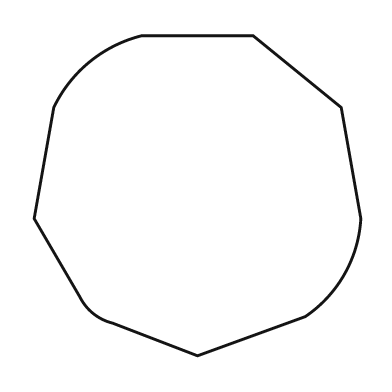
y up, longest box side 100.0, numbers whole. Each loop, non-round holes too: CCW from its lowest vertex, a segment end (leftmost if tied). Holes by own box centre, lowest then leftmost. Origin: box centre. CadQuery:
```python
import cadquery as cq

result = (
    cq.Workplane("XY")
    .moveTo(0.0, -49.0)
    .lineTo(33.0, -37.0)
    .threePointArc((45.0, -24.0), (50.0, -7.0))
    .lineTo(44.0, 27.0)
    .lineTo(17.0, 49.0)
    .lineTo(-17.0, 49.0)
    .threePointArc((-33.0, 41.0), (-44.0, 27.0))
    .lineTo(-50.0, -7.0)
    .lineTo(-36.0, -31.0)
    .threePointArc((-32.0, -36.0), (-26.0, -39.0))
    .close()
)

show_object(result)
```